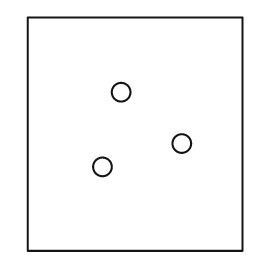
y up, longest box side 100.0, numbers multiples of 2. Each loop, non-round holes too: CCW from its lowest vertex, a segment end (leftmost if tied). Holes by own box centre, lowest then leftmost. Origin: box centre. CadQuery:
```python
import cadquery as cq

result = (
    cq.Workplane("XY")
    .moveTo(-46.0, -50.0)
    .lineTo(46.0, -50.0)
    .lineTo(46.0, 50.0)
    .lineTo(-46.0, 50.0)
    .close()
    .moveTo(-14.0, -14.0)
    .circle(4.0)
    .moveTo(20.0, -4.0)
    .circle(4.0)
    .moveTo(-6.0, 18.0)
    .circle(4.0)
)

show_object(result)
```